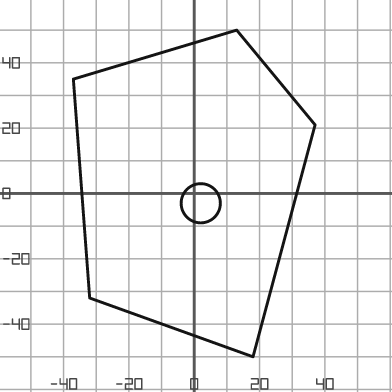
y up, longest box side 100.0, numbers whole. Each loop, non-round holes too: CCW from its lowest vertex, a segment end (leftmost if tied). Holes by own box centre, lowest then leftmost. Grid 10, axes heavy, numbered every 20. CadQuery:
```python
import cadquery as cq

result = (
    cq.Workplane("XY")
    .moveTo(18.0, -50.0)
    .lineTo(37.0, 21.0)
    .lineTo(13.0, 50.0)
    .lineTo(-37.0, 35.0)
    .lineTo(-32.0, -32.0)
    .close()
    .moveTo(2.0, -3.0)
    .circle(6.0)
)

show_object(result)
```